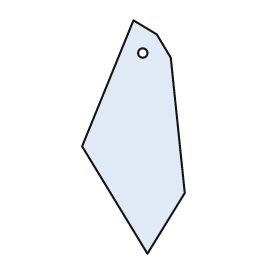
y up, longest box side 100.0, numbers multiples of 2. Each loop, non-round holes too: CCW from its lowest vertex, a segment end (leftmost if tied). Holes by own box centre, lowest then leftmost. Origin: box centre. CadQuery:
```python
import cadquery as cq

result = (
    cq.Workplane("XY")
    .moveTo(6.0, -50.0)
    .lineTo(22.0, -24.0)
    .lineTo(16.0, 34.0)
    .lineTo(10.0, 44.0)
    .lineTo(0.0, 50.0)
    .lineTo(-22.0, -4.0)
    .close()
    .moveTo(4.0, 36.0)
    .circle(2.0)
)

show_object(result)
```